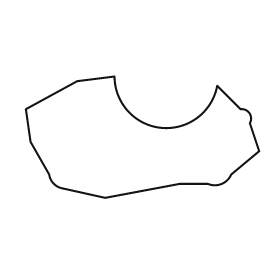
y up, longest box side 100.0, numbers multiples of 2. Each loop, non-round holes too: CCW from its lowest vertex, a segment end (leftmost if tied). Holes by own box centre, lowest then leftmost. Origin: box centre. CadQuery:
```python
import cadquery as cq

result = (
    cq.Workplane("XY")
    .moveTo(-16.0, -26.0)
    .lineTo(16.0, -20.0)
    .lineTo(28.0, -20.0)
    .threePointArc((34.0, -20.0), (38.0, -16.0))
    .lineTo(50.0, -6.0)
    .lineTo(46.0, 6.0)
    .threePointArc((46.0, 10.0), (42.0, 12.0))
    .lineTo(32.0, 22.0)
    .threePointArc((8.0, 4.0), (-12.0, 26.0))
    .lineTo(-28.0, 24.0)
    .lineTo(-50.0, 12.0)
    .lineTo(-48.0, -2.0)
    .lineTo(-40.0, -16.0)
    .threePointArc((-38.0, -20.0), (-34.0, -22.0))
    .close()
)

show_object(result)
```